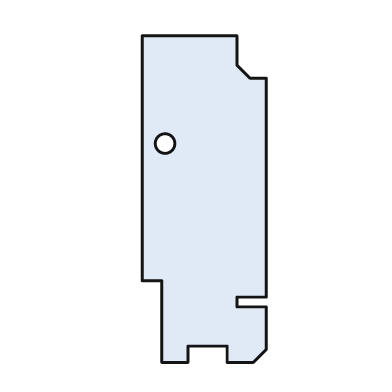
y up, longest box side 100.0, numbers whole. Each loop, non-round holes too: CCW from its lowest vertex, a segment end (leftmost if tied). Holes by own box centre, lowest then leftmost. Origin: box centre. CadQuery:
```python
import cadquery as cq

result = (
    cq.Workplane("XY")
    .moveTo(-13.0, -50.0)
    .lineTo(-5.0, -50.0)
    .lineTo(-5.0, -45.0)
    .lineTo(7.0, -45.0)
    .lineTo(7.0, -50.0)
    .lineTo(15.0, -50.0)
    .lineTo(19.0, -46.0)
    .lineTo(19.0, -33.0)
    .lineTo(10.0, -33.0)
    .lineTo(10.0, -30.0)
    .lineTo(19.0, -30.0)
    .lineTo(19.0, 37.0)
    .lineTo(14.0, 37.0)
    .lineTo(10.0, 41.0)
    .lineTo(10.0, 50.0)
    .lineTo(-19.0, 50.0)
    .lineTo(-19.0, -25.0)
    .lineTo(-13.0, -25.0)
    .close()
    .moveTo(-12.0, 17.0)
    .circle(3.0)
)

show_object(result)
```